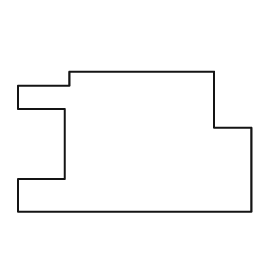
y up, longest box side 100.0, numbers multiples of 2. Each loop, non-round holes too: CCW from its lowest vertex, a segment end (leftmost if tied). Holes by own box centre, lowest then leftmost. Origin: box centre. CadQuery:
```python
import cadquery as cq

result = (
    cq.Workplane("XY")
    .moveTo(-50.0, -30.0)
    .lineTo(50.0, -30.0)
    .lineTo(50.0, 6.0)
    .lineTo(34.0, 6.0)
    .lineTo(34.0, 30.0)
    .lineTo(-28.0, 30.0)
    .lineTo(-28.0, 24.0)
    .lineTo(-50.0, 24.0)
    .lineTo(-50.0, 14.0)
    .lineTo(-30.0, 14.0)
    .lineTo(-30.0, -16.0)
    .lineTo(-50.0, -16.0)
    .close()
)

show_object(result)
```